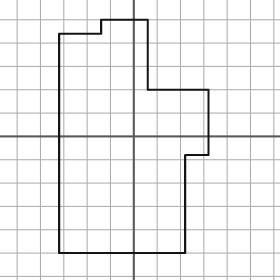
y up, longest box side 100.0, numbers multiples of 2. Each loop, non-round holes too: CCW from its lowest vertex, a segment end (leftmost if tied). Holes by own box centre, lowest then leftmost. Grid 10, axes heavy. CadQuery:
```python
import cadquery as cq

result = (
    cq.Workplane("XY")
    .moveTo(-32.0, -50.0)
    .lineTo(22.0, -50.0)
    .lineTo(22.0, -8.0)
    .lineTo(32.0, -8.0)
    .lineTo(32.0, 20.0)
    .lineTo(6.0, 20.0)
    .lineTo(6.0, 50.0)
    .lineTo(-14.0, 50.0)
    .lineTo(-14.0, 44.0)
    .lineTo(-32.0, 44.0)
    .close()
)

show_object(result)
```